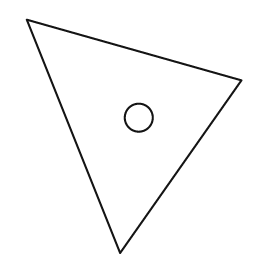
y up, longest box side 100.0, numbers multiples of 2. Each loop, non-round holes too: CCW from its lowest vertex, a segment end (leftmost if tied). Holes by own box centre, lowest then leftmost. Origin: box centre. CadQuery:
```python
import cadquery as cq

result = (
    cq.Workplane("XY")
    .moveTo(-6.0, -50.0)
    .lineTo(46.0, 24.0)
    .lineTo(-46.0, 50.0)
    .close()
    .moveTo(2.0, 8.0)
    .circle(6.0)
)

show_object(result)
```